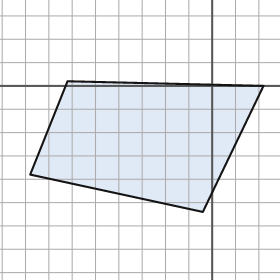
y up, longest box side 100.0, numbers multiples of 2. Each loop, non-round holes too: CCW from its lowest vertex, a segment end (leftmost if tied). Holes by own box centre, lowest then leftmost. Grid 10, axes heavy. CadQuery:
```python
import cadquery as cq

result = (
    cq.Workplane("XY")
    .moveTo(-4.0, -54.0)
    .lineTo(22.0, 0.0)
    .lineTo(-62.0, 2.0)
    .lineTo(-78.0, -38.0)
    .close()
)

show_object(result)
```